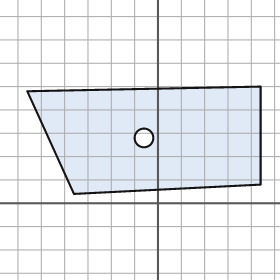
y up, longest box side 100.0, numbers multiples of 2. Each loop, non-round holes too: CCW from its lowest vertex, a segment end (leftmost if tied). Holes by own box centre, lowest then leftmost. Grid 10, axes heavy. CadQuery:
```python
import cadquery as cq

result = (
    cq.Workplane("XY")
    .moveTo(-36.0, 4.0)
    .lineTo(44.0, 8.0)
    .lineTo(44.0, 50.0)
    .lineTo(-56.0, 48.0)
    .close()
    .moveTo(-6.0, 28.0)
    .circle(4.0)
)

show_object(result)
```